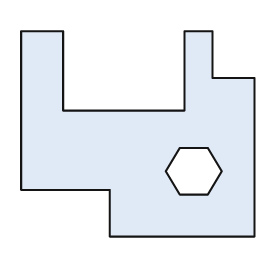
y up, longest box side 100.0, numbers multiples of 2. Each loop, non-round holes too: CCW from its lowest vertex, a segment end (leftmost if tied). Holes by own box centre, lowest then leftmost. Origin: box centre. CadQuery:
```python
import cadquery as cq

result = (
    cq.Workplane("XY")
    .moveTo(-12.0, -44.0)
    .lineTo(50.0, -44.0)
    .lineTo(50.0, 24.0)
    .lineTo(32.0, 24.0)
    .lineTo(32.0, 44.0)
    .lineTo(20.0, 44.0)
    .lineTo(20.0, 10.0)
    .lineTo(-32.0, 10.0)
    .lineTo(-32.0, 44.0)
    .lineTo(-50.0, 44.0)
    .lineTo(-50.0, -24.0)
    .lineTo(-12.0, -24.0)
    .close()
    .moveTo(18.0, -26.0)
    .lineTo(30.0, -26.0)
    .lineTo(36.0, -16.0)
    .lineTo(30.0, -6.0)
    .lineTo(18.0, -6.0)
    .lineTo(12.0, -16.0)
    .close()
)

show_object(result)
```